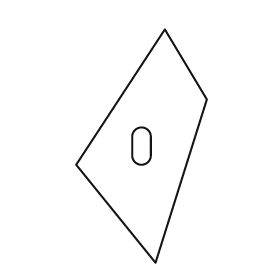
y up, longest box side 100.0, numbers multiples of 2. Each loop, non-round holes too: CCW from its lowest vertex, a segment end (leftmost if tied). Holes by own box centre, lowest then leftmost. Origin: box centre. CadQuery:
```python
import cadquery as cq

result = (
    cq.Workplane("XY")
    .moveTo(6.0, -50.0)
    .lineTo(28.0, 20.0)
    .lineTo(10.0, 50.0)
    .lineTo(-28.0, -8.0)
    .close()
    .moveTo(-4.0, -4.0)
    .threePointArc((0.0, -8.0), (4.0, -4.0))
    .lineTo(4.0, 4.0)
    .threePointArc((0.0, 8.0), (-4.0, 4.0))
    .close()
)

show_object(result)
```